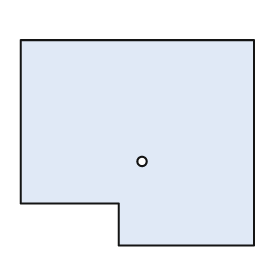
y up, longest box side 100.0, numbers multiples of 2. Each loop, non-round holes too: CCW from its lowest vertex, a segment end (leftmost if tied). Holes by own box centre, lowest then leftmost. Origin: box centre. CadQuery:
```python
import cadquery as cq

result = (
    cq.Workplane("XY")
    .moveTo(-8.0, -44.0)
    .lineTo(50.0, -44.0)
    .lineTo(50.0, 44.0)
    .lineTo(-50.0, 44.0)
    .lineTo(-50.0, -26.0)
    .lineTo(-8.0, -26.0)
    .close()
    .moveTo(2.0, -8.0)
    .circle(2.0)
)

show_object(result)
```